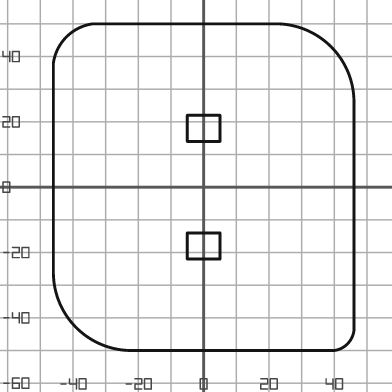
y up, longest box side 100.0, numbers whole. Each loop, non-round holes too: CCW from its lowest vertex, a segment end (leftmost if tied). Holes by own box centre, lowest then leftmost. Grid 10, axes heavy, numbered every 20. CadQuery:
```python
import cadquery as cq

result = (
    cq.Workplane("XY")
    .moveTo(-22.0, -50.0)
    .lineTo(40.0, -50.0)
    .threePointArc((44.0, -48.0), (46.0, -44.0))
    .lineTo(46.0, 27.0)
    .threePointArc((39.0, 43.0), (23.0, 50.0))
    .lineTo(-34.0, 50.0)
    .threePointArc((-42.0, 46.0), (-46.0, 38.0))
    .lineTo(-46.0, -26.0)
    .threePointArc((-39.0, -43.0), (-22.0, -50.0))
    .close()
    .moveTo(-5.0, -22.0)
    .lineTo(5.0, -22.0)
    .lineTo(5.0, -14.0)
    .lineTo(-5.0, -14.0)
    .close()
    .moveTo(-5.0, 14.0)
    .lineTo(5.0, 14.0)
    .lineTo(5.0, 22.0)
    .lineTo(-5.0, 22.0)
    .close()
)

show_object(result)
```